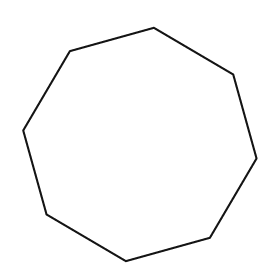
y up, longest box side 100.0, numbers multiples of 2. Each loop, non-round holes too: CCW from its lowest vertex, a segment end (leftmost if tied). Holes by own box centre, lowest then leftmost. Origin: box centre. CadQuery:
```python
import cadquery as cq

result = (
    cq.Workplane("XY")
    .moveTo(-6.0, -50.0)
    .lineTo(30.0, -40.0)
    .lineTo(50.0, -6.0)
    .lineTo(40.0, 30.0)
    .lineTo(6.0, 50.0)
    .lineTo(-30.0, 40.0)
    .lineTo(-50.0, 6.0)
    .lineTo(-40.0, -30.0)
    .close()
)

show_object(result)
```